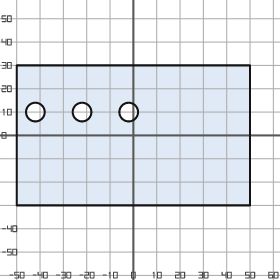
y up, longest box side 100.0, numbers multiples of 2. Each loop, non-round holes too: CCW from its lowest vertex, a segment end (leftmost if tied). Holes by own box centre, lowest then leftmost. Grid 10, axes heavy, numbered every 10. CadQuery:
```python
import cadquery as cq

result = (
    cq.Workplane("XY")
    .moveTo(-50.0, -30.0)
    .lineTo(50.0, -30.0)
    .lineTo(50.0, 30.0)
    .lineTo(-50.0, 30.0)
    .close()
    .moveTo(-42.0, 10.0)
    .circle(4.0)
    .moveTo(-22.0, 10.0)
    .circle(4.0)
    .moveTo(-2.0, 10.0)
    .circle(4.0)
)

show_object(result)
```